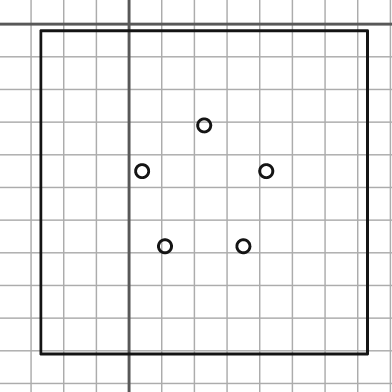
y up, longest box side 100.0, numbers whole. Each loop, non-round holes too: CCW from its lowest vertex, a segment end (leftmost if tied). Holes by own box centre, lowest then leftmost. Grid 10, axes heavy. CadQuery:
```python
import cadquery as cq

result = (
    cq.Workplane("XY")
    .moveTo(-27.0, -101.0)
    .lineTo(73.0, -101.0)
    .lineTo(73.0, -2.0)
    .lineTo(-27.0, -2.0)
    .close()
    .moveTo(11.0, -68.0)
    .circle(2.0)
    .moveTo(35.0, -68.0)
    .circle(2.0)
    .moveTo(4.0, -45.0)
    .circle(2.0)
    .moveTo(42.0, -45.0)
    .circle(2.0)
    .moveTo(23.0, -31.0)
    .circle(2.0)
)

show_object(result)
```